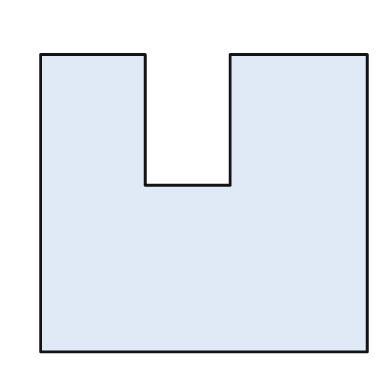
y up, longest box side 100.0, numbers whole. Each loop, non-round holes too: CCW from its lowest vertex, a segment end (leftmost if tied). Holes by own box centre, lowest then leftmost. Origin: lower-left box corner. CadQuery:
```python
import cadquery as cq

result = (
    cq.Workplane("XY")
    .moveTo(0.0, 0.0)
    .lineTo(100.0, 0.0)
    .lineTo(100.0, 91.0)
    .lineTo(58.0, 91.0)
    .lineTo(58.0, 51.0)
    .lineTo(32.0, 51.0)
    .lineTo(32.0, 91.0)
    .lineTo(0.0, 91.0)
    .close()
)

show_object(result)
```